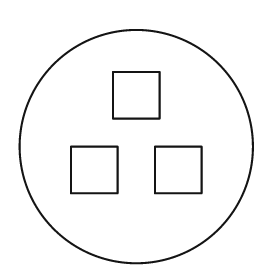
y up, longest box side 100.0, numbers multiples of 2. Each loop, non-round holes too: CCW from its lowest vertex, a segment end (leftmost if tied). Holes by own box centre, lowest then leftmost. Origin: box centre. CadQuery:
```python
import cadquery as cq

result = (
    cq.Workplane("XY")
    .moveTo(0.0, 0.0)
    .circle(50.0)
    .moveTo(-28.0, -20.0)
    .lineTo(-8.0, -20.0)
    .lineTo(-8.0, 0.0)
    .lineTo(-28.0, 0.0)
    .close()
    .moveTo(8.0, -20.0)
    .lineTo(28.0, -20.0)
    .lineTo(28.0, 0.0)
    .lineTo(8.0, 0.0)
    .close()
    .moveTo(-10.0, 12.0)
    .lineTo(10.0, 12.0)
    .lineTo(10.0, 32.0)
    .lineTo(-10.0, 32.0)
    .close()
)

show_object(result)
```